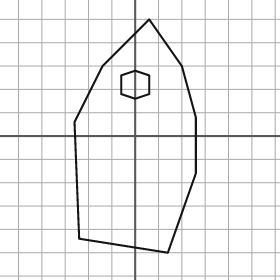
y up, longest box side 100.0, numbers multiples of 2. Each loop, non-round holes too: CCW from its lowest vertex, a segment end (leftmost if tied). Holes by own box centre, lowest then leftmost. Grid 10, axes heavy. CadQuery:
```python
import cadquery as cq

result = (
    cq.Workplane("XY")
    .moveTo(14.0, -50.0)
    .lineTo(26.0, -16.0)
    .lineTo(26.0, 8.0)
    .lineTo(20.0, 30.0)
    .lineTo(6.0, 50.0)
    .lineTo(-14.0, 30.0)
    .lineTo(-26.0, 6.0)
    .lineTo(-24.0, -44.0)
    .close()
    .moveTo(0.0, 16.0)
    .lineTo(6.0, 18.0)
    .lineTo(6.0, 26.0)
    .lineTo(0.0, 28.0)
    .lineTo(-6.0, 26.0)
    .lineTo(-6.0, 18.0)
    .close()
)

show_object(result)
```